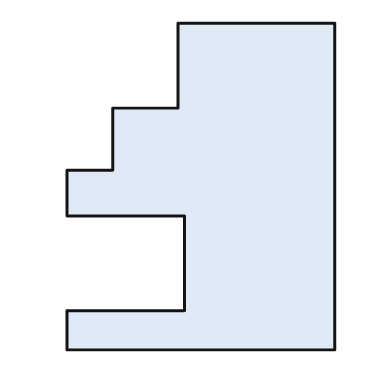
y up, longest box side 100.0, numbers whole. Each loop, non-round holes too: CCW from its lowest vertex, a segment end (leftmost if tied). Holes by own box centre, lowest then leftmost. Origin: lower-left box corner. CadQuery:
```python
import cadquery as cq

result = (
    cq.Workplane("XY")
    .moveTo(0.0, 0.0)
    .lineTo(82.0, 0.0)
    .lineTo(82.0, 100.0)
    .lineTo(34.0, 100.0)
    .lineTo(34.0, 74.0)
    .lineTo(14.0, 74.0)
    .lineTo(14.0, 55.0)
    .lineTo(0.0, 55.0)
    .lineTo(0.0, 41.0)
    .lineTo(36.0, 41.0)
    .lineTo(36.0, 12.0)
    .lineTo(0.0, 12.0)
    .close()
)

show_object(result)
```